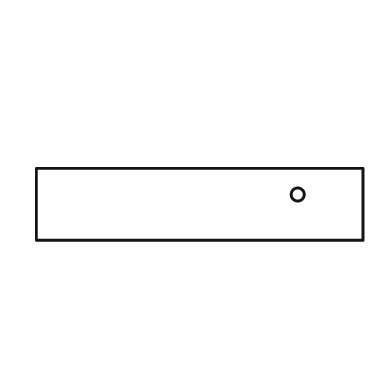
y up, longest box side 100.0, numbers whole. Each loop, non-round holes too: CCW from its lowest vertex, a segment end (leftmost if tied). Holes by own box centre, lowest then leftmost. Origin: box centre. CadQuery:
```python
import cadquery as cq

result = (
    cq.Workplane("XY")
    .moveTo(-50.0, -11.0)
    .lineTo(50.0, -11.0)
    .lineTo(50.0, 11.0)
    .lineTo(-50.0, 11.0)
    .close()
    .moveTo(30.0, 3.0)
    .circle(2.0)
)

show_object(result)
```